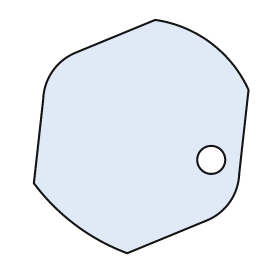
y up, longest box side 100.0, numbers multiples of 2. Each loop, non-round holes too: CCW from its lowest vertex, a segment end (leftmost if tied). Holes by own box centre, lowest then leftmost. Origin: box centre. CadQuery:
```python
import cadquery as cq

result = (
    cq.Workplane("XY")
    .moveTo(-6.0, -50.0)
    .lineTo(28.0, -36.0)
    .threePointArc((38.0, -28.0), (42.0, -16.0))
    .lineTo(46.0, 20.0)
    .threePointArc((30.0, 40.0), (6.0, 50.0))
    .lineTo(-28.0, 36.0)
    .threePointArc((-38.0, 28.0), (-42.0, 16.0))
    .lineTo(-46.0, -20.0)
    .threePointArc((-28.0, -38.0), (-6.0, -50.0))
    .close()
    .moveTo(30.0, -10.0)
    .circle(6.0)
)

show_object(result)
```